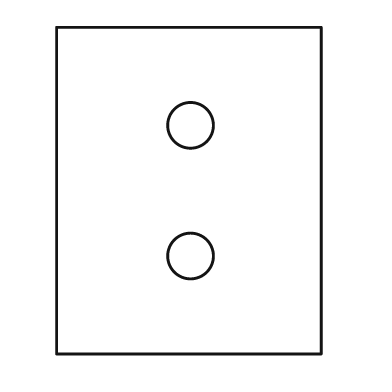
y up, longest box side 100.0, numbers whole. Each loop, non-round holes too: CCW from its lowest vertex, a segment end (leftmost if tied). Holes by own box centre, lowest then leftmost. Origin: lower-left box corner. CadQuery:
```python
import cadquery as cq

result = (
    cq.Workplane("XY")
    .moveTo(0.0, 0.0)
    .lineTo(81.0, 0.0)
    .lineTo(81.0, 100.0)
    .lineTo(0.0, 100.0)
    .close()
    .moveTo(41.0, 30.0)
    .circle(7.0)
    .moveTo(41.0, 70.0)
    .circle(7.0)
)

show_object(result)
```